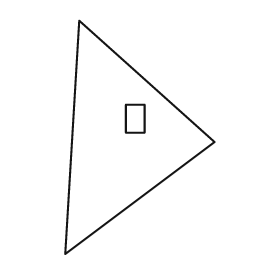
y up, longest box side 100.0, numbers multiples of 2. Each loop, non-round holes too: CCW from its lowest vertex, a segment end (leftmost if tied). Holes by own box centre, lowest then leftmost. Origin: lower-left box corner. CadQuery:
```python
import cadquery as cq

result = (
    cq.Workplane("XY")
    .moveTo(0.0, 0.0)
    .lineTo(64.0, 48.0)
    .lineTo(6.0, 100.0)
    .close()
    .moveTo(26.0, 52.0)
    .lineTo(34.0, 52.0)
    .lineTo(34.0, 64.0)
    .lineTo(26.0, 64.0)
    .close()
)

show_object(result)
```